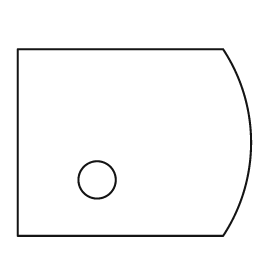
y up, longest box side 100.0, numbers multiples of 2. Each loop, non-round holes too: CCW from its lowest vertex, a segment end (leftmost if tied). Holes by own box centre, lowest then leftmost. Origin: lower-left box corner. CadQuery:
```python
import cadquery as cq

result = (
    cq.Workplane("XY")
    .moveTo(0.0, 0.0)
    .lineTo(88.0, 0.0)
    .threePointArc((100.0, 40.0), (88.0, 80.0))
    .lineTo(0.0, 80.0)
    .close()
    .moveTo(34.0, 24.0)
    .circle(8.0)
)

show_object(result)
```